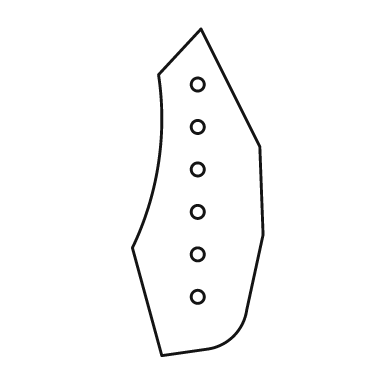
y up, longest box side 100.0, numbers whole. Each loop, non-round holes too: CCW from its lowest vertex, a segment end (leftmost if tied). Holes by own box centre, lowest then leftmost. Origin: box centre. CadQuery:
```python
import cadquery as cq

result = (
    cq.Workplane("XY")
    .moveTo(-11.0, -50.0)
    .lineTo(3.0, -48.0)
    .threePointArc((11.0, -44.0), (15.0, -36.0))
    .lineTo(20.0, -13.0)
    .lineTo(19.0, 14.0)
    .lineTo(1.0, 50.0)
    .lineTo(-12.0, 36.0)
    .threePointArc((-12.0, 9.0), (-20.0, -17.0))
    .close()
    .moveTo(0.0, -32.0)
    .circle(2.0)
    .moveTo(0.0, -19.0)
    .circle(2.0)
    .moveTo(0.0, -6.0)
    .circle(2.0)
    .moveTo(0.0, 7.0)
    .circle(2.0)
    .moveTo(0.0, 20.0)
    .circle(2.0)
    .moveTo(0.0, 33.0)
    .circle(2.0)
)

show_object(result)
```